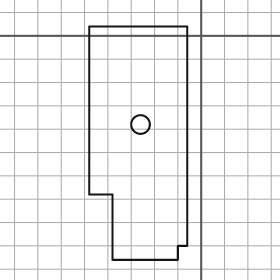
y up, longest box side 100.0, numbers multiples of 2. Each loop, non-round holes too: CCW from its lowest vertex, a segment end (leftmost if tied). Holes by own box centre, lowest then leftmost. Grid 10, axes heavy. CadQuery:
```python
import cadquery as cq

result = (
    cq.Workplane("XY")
    .moveTo(-38.0, -96.0)
    .lineTo(-10.0, -96.0)
    .lineTo(-10.0, -90.0)
    .lineTo(-6.0, -90.0)
    .lineTo(-6.0, 4.0)
    .lineTo(-48.0, 4.0)
    .lineTo(-48.0, -68.0)
    .lineTo(-38.0, -68.0)
    .close()
    .moveTo(-26.0, -38.0)
    .circle(4.0)
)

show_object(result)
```